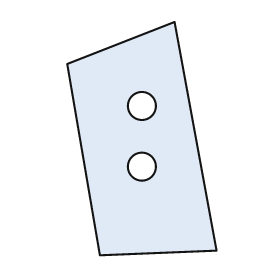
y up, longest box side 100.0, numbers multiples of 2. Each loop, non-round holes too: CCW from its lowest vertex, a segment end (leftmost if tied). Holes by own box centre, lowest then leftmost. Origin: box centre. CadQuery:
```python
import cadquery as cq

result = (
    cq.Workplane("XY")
    .moveTo(-18.0, -50.0)
    .lineTo(32.0, -48.0)
    .lineTo(14.0, 50.0)
    .lineTo(-32.0, 32.0)
    .close()
    .moveTo(0.0, -12.0)
    .circle(6.0)
    .moveTo(0.0, 14.0)
    .circle(6.0)
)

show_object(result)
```